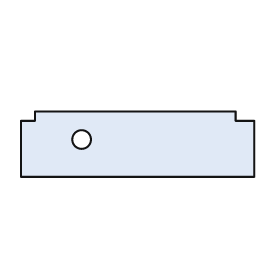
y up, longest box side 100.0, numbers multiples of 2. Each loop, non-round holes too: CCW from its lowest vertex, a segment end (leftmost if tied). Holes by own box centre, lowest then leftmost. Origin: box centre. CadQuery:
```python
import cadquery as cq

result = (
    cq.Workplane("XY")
    .moveTo(-50.0, -14.0)
    .lineTo(50.0, -14.0)
    .lineTo(50.0, 10.0)
    .lineTo(42.0, 10.0)
    .lineTo(42.0, 14.0)
    .lineTo(-44.0, 14.0)
    .lineTo(-44.0, 10.0)
    .lineTo(-50.0, 10.0)
    .close()
    .moveTo(-24.0, 2.0)
    .circle(4.0)
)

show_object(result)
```